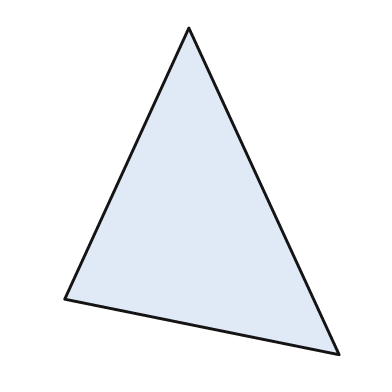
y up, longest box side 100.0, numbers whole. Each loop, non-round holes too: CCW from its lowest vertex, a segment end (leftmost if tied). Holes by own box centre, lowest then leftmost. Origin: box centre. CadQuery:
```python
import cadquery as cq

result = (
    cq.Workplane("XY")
    .moveTo(42.0, -50.0)
    .lineTo(-4.0, 50.0)
    .lineTo(-42.0, -33.0)
    .close()
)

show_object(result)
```